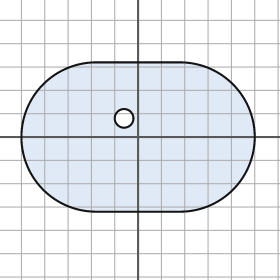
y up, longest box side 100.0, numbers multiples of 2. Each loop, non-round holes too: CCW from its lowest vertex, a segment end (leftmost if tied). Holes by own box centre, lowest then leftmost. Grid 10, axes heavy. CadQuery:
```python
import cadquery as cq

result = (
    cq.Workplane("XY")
    .moveTo(-18.0, -32.0)
    .lineTo(18.0, -32.0)
    .threePointArc((50.0, 0.0), (18.0, 32.0))
    .lineTo(-18.0, 32.0)
    .threePointArc((-50.0, 0.0), (-18.0, -32.0))
    .close()
    .moveTo(-6.0, 8.0)
    .circle(4.0)
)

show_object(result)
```